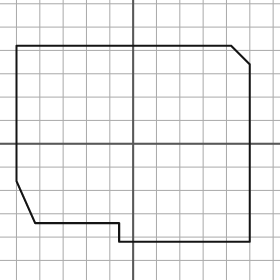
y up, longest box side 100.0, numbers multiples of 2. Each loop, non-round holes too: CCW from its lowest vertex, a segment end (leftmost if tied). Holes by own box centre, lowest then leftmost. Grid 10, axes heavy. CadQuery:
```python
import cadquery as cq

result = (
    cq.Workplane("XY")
    .moveTo(-6.0, -42.0)
    .lineTo(50.0, -42.0)
    .lineTo(50.0, 34.0)
    .lineTo(42.0, 42.0)
    .lineTo(-50.0, 42.0)
    .lineTo(-50.0, -16.0)
    .lineTo(-42.0, -34.0)
    .lineTo(-6.0, -34.0)
    .close()
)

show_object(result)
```